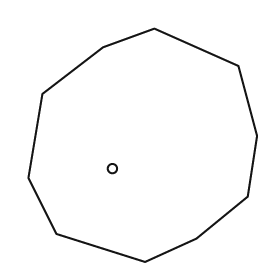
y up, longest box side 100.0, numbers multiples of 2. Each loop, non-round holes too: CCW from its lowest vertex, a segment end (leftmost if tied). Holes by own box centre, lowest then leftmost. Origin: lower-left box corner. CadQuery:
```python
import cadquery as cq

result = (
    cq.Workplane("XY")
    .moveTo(50.0, 0.0)
    .lineTo(72.0, 10.0)
    .lineTo(94.0, 28.0)
    .lineTo(98.0, 54.0)
    .lineTo(90.0, 84.0)
    .lineTo(54.0, 100.0)
    .lineTo(32.0, 92.0)
    .lineTo(6.0, 72.0)
    .lineTo(0.0, 36.0)
    .lineTo(12.0, 12.0)
    .close()
    .moveTo(36.0, 40.0)
    .circle(2.0)
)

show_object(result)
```